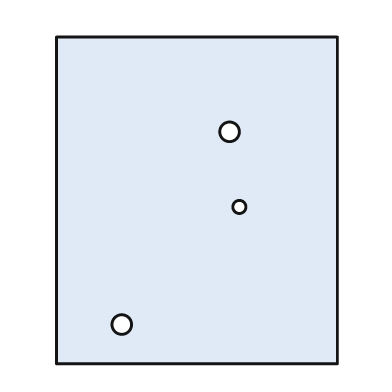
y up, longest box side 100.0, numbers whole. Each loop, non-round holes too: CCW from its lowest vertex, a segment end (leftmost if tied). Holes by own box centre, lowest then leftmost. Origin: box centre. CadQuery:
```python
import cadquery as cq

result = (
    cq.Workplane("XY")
    .moveTo(-43.0, -50.0)
    .lineTo(43.0, -50.0)
    .lineTo(43.0, 50.0)
    .lineTo(-43.0, 50.0)
    .close()
    .moveTo(-23.0, -38.0)
    .circle(3.0)
    .moveTo(13.0, -2.0)
    .circle(2.0)
    .moveTo(10.0, 21.0)
    .circle(3.0)
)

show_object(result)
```